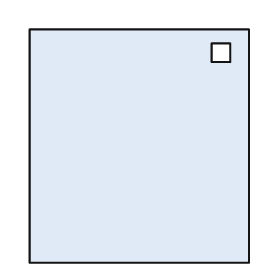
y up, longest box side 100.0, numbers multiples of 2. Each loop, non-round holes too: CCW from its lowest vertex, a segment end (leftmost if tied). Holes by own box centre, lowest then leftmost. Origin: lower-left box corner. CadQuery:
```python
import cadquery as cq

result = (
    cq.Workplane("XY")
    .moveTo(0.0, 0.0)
    .lineTo(94.0, 0.0)
    .lineTo(94.0, 100.0)
    .lineTo(0.0, 100.0)
    .close()
    .moveTo(78.0, 86.0)
    .lineTo(86.0, 86.0)
    .lineTo(86.0, 94.0)
    .lineTo(78.0, 94.0)
    .close()
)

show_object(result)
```